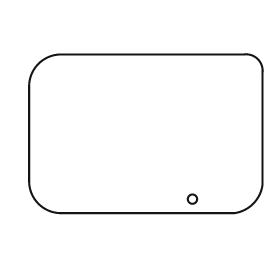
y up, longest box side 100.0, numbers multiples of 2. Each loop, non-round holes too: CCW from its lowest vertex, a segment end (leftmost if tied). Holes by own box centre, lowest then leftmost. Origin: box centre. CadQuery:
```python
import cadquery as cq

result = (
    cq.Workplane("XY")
    .moveTo(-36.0, -34.0)
    .lineTo(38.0, -34.0)
    .threePointArc((46.0, -30.0), (50.0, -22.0))
    .lineTo(50.0, 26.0)
    .threePointArc((48.0, 32.0), (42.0, 34.0))
    .lineTo(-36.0, 34.0)
    .threePointArc((-46.0, 30.0), (-50.0, 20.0))
    .lineTo(-50.0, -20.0)
    .threePointArc((-46.0, -30.0), (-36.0, -34.0))
    .close()
    .moveTo(20.0, -28.0)
    .circle(2.0)
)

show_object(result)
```